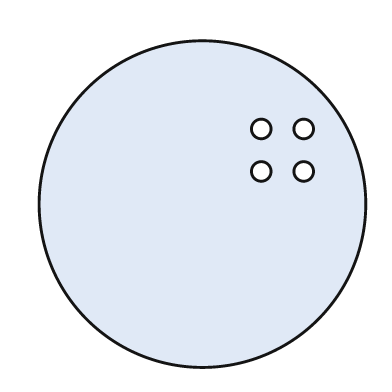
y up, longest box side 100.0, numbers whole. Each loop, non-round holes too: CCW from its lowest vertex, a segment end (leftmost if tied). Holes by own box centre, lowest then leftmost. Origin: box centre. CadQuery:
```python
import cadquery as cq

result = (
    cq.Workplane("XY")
    .moveTo(0.0, 0.0)
    .circle(50.0)
    .moveTo(18.0, 10.0)
    .circle(3.0)
    .moveTo(31.0, 10.0)
    .circle(3.0)
    .moveTo(18.0, 23.0)
    .circle(3.0)
    .moveTo(31.0, 23.0)
    .circle(3.0)
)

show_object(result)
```